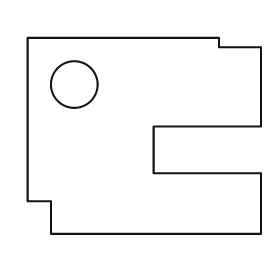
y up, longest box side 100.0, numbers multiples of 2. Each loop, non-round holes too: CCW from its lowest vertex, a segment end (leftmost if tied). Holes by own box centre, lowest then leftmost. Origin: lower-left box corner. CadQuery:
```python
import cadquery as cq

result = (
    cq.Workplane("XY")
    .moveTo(10.0, 0.0)
    .lineTo(100.0, 0.0)
    .lineTo(100.0, 26.0)
    .lineTo(54.0, 26.0)
    .lineTo(54.0, 46.0)
    .lineTo(100.0, 46.0)
    .lineTo(100.0, 80.0)
    .lineTo(82.0, 80.0)
    .lineTo(82.0, 84.0)
    .lineTo(0.0, 84.0)
    .lineTo(0.0, 14.0)
    .lineTo(10.0, 14.0)
    .close()
    .moveTo(20.0, 64.0)
    .circle(10.0)
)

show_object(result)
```